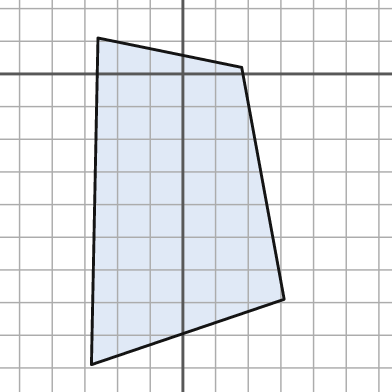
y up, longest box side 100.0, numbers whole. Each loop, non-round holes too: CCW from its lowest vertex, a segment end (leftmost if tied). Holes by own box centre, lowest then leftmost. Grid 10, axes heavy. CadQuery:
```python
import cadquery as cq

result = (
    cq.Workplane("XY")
    .moveTo(-28.0, -89.0)
    .lineTo(31.0, -69.0)
    .lineTo(18.0, 2.0)
    .lineTo(-26.0, 11.0)
    .close()
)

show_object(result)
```